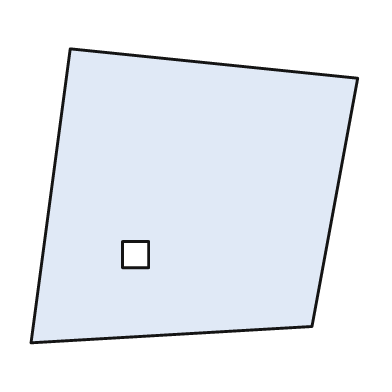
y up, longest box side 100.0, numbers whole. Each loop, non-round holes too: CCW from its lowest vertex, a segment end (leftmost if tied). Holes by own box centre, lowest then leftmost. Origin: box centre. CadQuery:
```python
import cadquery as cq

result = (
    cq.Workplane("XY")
    .moveTo(-50.0, -45.0)
    .lineTo(36.0, -40.0)
    .lineTo(50.0, 36.0)
    .lineTo(-38.0, 45.0)
    .close()
    .moveTo(-22.0, -22.0)
    .lineTo(-14.0, -22.0)
    .lineTo(-14.0, -14.0)
    .lineTo(-22.0, -14.0)
    .close()
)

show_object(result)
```